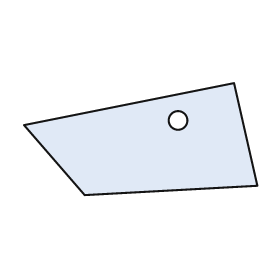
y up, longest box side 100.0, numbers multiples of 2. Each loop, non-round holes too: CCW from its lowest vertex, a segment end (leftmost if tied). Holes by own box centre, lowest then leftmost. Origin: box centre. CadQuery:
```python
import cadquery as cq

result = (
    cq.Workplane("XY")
    .moveTo(-24.0, -24.0)
    .lineTo(50.0, -20.0)
    .lineTo(40.0, 24.0)
    .lineTo(-50.0, 6.0)
    .close()
    .moveTo(16.0, 8.0)
    .circle(4.0)
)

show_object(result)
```